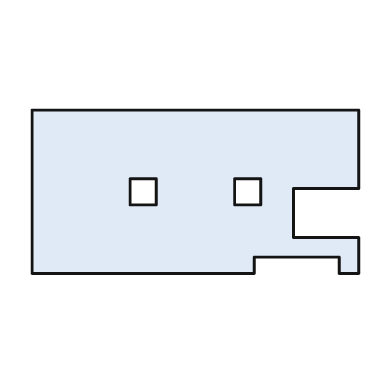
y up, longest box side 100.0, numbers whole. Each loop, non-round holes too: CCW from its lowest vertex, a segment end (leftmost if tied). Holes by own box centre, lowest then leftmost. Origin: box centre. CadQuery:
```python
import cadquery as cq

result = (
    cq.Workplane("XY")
    .moveTo(-50.0, -25.0)
    .lineTo(18.0, -25.0)
    .lineTo(18.0, -20.0)
    .lineTo(44.0, -20.0)
    .lineTo(44.0, -25.0)
    .lineTo(50.0, -25.0)
    .lineTo(50.0, -14.0)
    .lineTo(30.0, -14.0)
    .lineTo(30.0, 1.0)
    .lineTo(50.0, 1.0)
    .lineTo(50.0, 25.0)
    .lineTo(-50.0, 25.0)
    .close()
    .moveTo(-20.0, -4.0)
    .lineTo(-12.0, -4.0)
    .lineTo(-12.0, 4.0)
    .lineTo(-20.0, 4.0)
    .close()
    .moveTo(12.0, -4.0)
    .lineTo(20.0, -4.0)
    .lineTo(20.0, 4.0)
    .lineTo(12.0, 4.0)
    .close()
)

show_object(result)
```